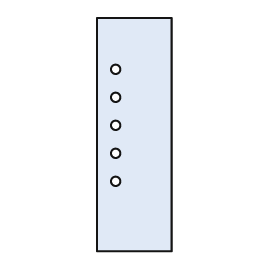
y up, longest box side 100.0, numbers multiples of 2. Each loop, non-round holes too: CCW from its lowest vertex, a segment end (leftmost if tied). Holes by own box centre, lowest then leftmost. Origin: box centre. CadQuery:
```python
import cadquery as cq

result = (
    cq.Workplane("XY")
    .moveTo(-16.0, -50.0)
    .lineTo(16.0, -50.0)
    .lineTo(16.0, 50.0)
    .lineTo(-16.0, 50.0)
    .close()
    .moveTo(-8.0, -20.0)
    .circle(2.0)
    .moveTo(-8.0, -8.0)
    .circle(2.0)
    .moveTo(-8.0, 4.0)
    .circle(2.0)
    .moveTo(-8.0, 16.0)
    .circle(2.0)
    .moveTo(-8.0, 28.0)
    .circle(2.0)
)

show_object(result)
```